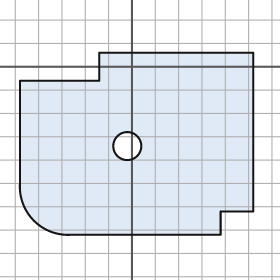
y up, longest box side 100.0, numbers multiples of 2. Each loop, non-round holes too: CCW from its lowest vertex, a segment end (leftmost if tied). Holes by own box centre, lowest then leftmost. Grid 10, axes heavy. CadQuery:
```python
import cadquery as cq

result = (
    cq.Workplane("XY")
    .moveTo(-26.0, -72.0)
    .lineTo(38.0, -72.0)
    .lineTo(38.0, -62.0)
    .lineTo(52.0, -62.0)
    .lineTo(52.0, 6.0)
    .lineTo(-14.0, 6.0)
    .lineTo(-14.0, -6.0)
    .lineTo(-48.0, -6.0)
    .lineTo(-48.0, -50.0)
    .threePointArc((-42.0, -66.0), (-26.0, -72.0))
    .close()
    .moveTo(-2.0, -34.0)
    .circle(6.0)
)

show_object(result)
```